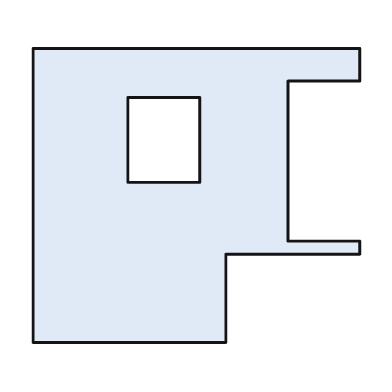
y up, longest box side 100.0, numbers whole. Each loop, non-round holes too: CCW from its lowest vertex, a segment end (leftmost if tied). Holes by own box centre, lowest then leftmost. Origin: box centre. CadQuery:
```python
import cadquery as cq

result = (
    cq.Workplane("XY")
    .moveTo(-50.0, -45.0)
    .lineTo(9.0, -45.0)
    .lineTo(9.0, -18.0)
    .lineTo(50.0, -18.0)
    .lineTo(50.0, -14.0)
    .lineTo(28.0, -14.0)
    .lineTo(28.0, 35.0)
    .lineTo(50.0, 35.0)
    .lineTo(50.0, 45.0)
    .lineTo(-50.0, 45.0)
    .close()
    .moveTo(-21.0, 4.0)
    .lineTo(1.0, 4.0)
    .lineTo(1.0, 30.0)
    .lineTo(-21.0, 30.0)
    .close()
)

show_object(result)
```